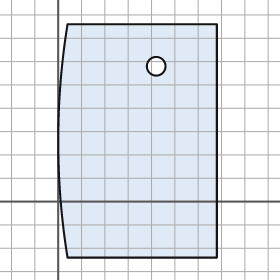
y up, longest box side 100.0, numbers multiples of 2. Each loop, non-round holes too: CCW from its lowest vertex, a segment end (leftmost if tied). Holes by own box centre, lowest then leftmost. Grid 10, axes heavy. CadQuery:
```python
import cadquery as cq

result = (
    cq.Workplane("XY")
    .moveTo(4.0, -24.0)
    .lineTo(68.0, -24.0)
    .lineTo(68.0, 76.0)
    .lineTo(4.0, 76.0)
    .threePointArc((0.0, 26.0), (4.0, -24.0))
    .close()
    .moveTo(42.0, 58.0)
    .circle(4.0)
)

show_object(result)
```